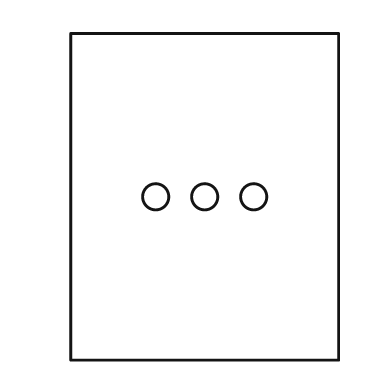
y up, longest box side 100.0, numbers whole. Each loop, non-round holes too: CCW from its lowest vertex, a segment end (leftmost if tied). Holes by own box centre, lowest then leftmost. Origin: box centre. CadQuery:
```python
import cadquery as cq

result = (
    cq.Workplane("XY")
    .moveTo(-41.0, -50.0)
    .lineTo(41.0, -50.0)
    .lineTo(41.0, 50.0)
    .lineTo(-41.0, 50.0)
    .close()
    .moveTo(-15.0, 0.0)
    .circle(4.0)
    .moveTo(0.0, 0.0)
    .circle(4.0)
    .moveTo(15.0, 0.0)
    .circle(4.0)
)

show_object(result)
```